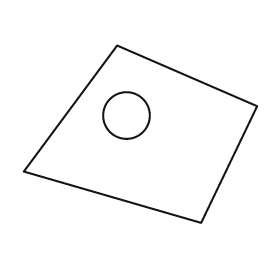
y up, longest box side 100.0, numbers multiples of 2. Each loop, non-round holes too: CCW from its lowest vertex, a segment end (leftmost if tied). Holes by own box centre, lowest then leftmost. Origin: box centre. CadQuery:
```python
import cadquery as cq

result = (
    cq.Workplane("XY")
    .moveTo(26.0, -38.0)
    .lineTo(50.0, 12.0)
    .lineTo(-10.0, 38.0)
    .lineTo(-50.0, -16.0)
    .close()
    .moveTo(-6.0, 8.0)
    .circle(10.0)
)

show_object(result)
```